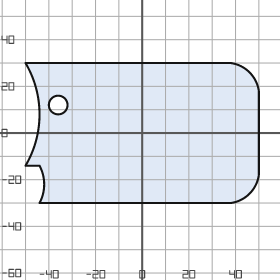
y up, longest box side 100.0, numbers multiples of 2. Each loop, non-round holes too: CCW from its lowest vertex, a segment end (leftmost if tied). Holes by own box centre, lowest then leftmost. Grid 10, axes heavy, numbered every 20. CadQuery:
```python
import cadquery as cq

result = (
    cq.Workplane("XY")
    .moveTo(-44.0, -30.0)
    .lineTo(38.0, -30.0)
    .threePointArc((46.0, -26.0), (50.0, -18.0))
    .lineTo(50.0, 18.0)
    .threePointArc((46.0, 26.0), (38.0, 30.0))
    .lineTo(-50.0, 30.0)
    .threePointArc((-44.0, 8.0), (-50.0, -14.0))
    .lineTo(-44.0, -14.0)
    .threePointArc((-42.0, -22.0), (-44.0, -30.0))
    .close()
    .moveTo(-36.0, 12.0)
    .circle(4.0)
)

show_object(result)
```